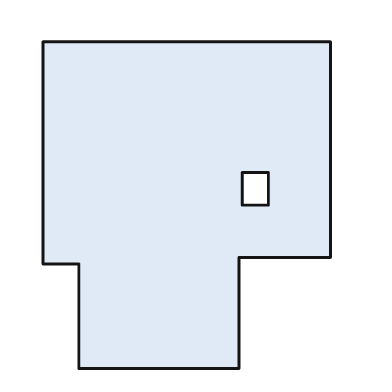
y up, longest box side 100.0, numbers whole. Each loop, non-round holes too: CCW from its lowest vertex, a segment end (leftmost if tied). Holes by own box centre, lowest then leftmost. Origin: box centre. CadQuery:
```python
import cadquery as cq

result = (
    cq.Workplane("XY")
    .moveTo(-33.0, -50.0)
    .lineTo(16.0, -50.0)
    .lineTo(16.0, -16.0)
    .lineTo(44.0, -16.0)
    .lineTo(44.0, 50.0)
    .lineTo(-44.0, 50.0)
    .lineTo(-44.0, -18.0)
    .lineTo(-33.0, -18.0)
    .close()
    .moveTo(17.0, 0.0)
    .lineTo(25.0, 0.0)
    .lineTo(25.0, 10.0)
    .lineTo(17.0, 10.0)
    .close()
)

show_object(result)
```